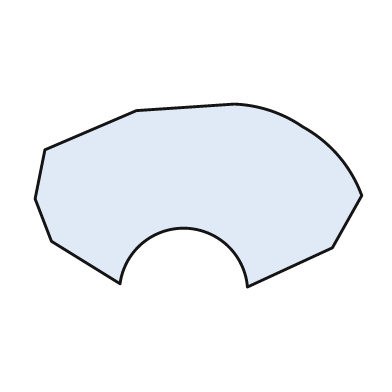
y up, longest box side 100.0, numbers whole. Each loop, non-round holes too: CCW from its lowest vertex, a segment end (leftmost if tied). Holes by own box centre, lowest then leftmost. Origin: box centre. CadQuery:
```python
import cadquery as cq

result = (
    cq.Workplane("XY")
    .moveTo(15.0, -28.0)
    .lineTo(41.0, -16.0)
    .lineTo(50.0, 0.0)
    .threePointArc((43.0, 12.0), (32.0, 21.0))
    .threePointArc((22.0, 26.0), (11.0, 28.0))
    .lineTo(-19.0, 26.0)
    .lineTo(-47.0, 14.0)
    .lineTo(-50.0, -1.0)
    .lineTo(-45.0, -14.0)
    .lineTo(-24.0, -27.0)
    .threePointArc((-4.0, -10.0), (15.0, -28.0))
    .close()
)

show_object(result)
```